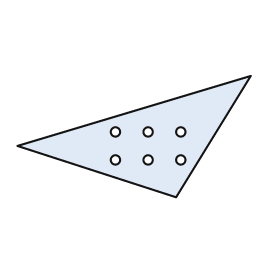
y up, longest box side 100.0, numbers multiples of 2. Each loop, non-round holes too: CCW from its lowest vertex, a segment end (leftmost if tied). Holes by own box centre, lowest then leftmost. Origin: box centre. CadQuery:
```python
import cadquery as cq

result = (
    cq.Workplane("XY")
    .moveTo(18.0, -26.0)
    .lineTo(50.0, 26.0)
    .lineTo(-50.0, -4.0)
    .close()
    .moveTo(-8.0, -10.0)
    .circle(2.0)
    .moveTo(6.0, -10.0)
    .circle(2.0)
    .moveTo(20.0, -10.0)
    .circle(2.0)
    .moveTo(-8.0, 2.0)
    .circle(2.0)
    .moveTo(6.0, 2.0)
    .circle(2.0)
    .moveTo(20.0, 2.0)
    .circle(2.0)
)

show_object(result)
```